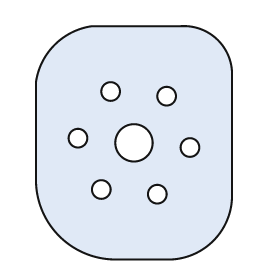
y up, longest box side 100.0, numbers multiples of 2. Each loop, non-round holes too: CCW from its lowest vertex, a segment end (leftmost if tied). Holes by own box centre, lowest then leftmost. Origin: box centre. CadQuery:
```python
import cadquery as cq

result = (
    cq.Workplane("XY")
    .moveTo(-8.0, -50.0)
    .lineTo(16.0, -50.0)
    .threePointArc((34.0, -42.0), (42.0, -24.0))
    .lineTo(42.0, 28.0)
    .threePointArc((36.0, 44.0), (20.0, 50.0))
    .lineTo(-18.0, 50.0)
    .threePointArc((-34.0, 42.0), (-42.0, 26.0))
    .lineTo(-42.0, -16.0)
    .threePointArc((-32.0, -40.0), (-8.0, -50.0))
    .close()
    .moveTo(10.0, -22.0)
    .circle(4.0)
    .moveTo(-14.0, -20.0)
    .circle(4.0)
    .moveTo(24.0, -2.0)
    .circle(4.0)
    .moveTo(0.0, 0.0)
    .circle(8.0)
    .moveTo(-24.0, 2.0)
    .circle(4.0)
    .moveTo(14.0, 20.0)
    .circle(4.0)
    .moveTo(-10.0, 22.0)
    .circle(4.0)
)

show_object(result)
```